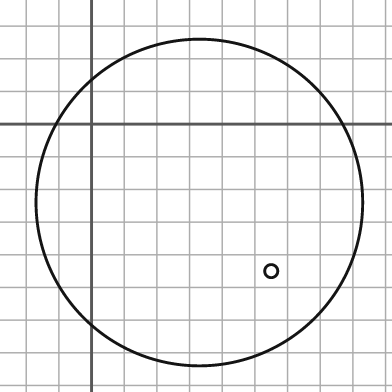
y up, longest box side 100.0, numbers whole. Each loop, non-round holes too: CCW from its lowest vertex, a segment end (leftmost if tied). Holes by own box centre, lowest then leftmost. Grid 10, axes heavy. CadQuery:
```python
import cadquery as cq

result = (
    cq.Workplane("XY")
    .moveTo(33.0, -24.0)
    .circle(50.0)
    .moveTo(55.0, -45.0)
    .circle(2.0)
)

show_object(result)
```